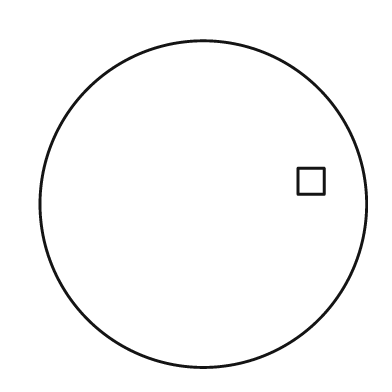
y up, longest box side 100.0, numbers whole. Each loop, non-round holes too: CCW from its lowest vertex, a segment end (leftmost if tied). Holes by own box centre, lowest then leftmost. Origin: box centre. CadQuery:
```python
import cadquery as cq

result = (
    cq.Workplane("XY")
    .moveTo(0.0, 0.0)
    .circle(50.0)
    .moveTo(29.0, 3.0)
    .lineTo(37.0, 3.0)
    .lineTo(37.0, 11.0)
    .lineTo(29.0, 11.0)
    .close()
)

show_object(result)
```